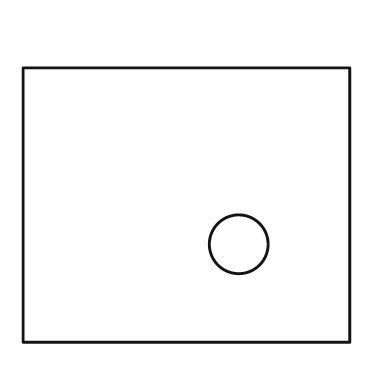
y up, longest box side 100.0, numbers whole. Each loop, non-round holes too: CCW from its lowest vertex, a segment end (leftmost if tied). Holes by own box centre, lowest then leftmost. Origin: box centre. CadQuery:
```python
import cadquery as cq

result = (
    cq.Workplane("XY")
    .moveTo(-50.0, -42.0)
    .lineTo(50.0, -42.0)
    .lineTo(50.0, 42.0)
    .lineTo(-50.0, 42.0)
    .close()
    .moveTo(16.0, -12.0)
    .circle(9.0)
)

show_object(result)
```